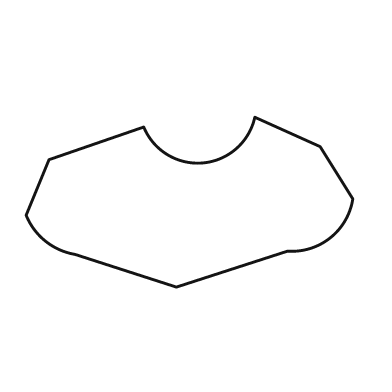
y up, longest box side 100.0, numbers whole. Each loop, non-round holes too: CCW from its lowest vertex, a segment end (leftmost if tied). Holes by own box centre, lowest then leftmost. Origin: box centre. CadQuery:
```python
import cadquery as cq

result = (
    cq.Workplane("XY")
    .moveTo(-4.0, -26.0)
    .lineTo(30.0, -15.0)
    .threePointArc((43.0, -11.0), (50.0, 1.0))
    .lineTo(40.0, 17.0)
    .lineTo(20.0, 26.0)
    .threePointArc((4.0, 12.0), (-14.0, 23.0))
    .lineTo(-43.0, 13.0)
    .lineTo(-50.0, -4.0)
    .threePointArc((-44.0, -12.0), (-35.0, -16.0))
    .close()
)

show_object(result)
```